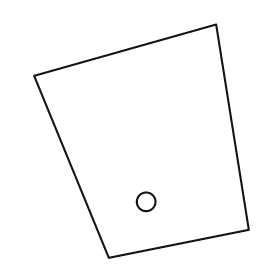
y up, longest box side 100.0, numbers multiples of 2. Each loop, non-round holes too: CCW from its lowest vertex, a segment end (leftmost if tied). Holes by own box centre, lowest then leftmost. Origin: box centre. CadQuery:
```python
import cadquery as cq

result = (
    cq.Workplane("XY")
    .moveTo(-14.0, -50.0)
    .lineTo(46.0, -38.0)
    .lineTo(32.0, 50.0)
    .lineTo(-46.0, 28.0)
    .close()
    .moveTo(2.0, -26.0)
    .circle(4.0)
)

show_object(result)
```